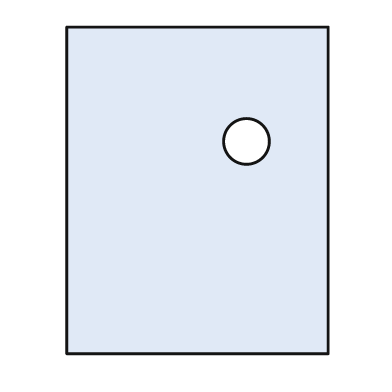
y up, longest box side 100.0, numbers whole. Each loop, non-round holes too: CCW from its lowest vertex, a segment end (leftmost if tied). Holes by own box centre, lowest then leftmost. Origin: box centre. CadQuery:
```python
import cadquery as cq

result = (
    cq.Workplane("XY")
    .moveTo(-40.0, -50.0)
    .lineTo(40.0, -50.0)
    .lineTo(40.0, 50.0)
    .lineTo(-40.0, 50.0)
    .close()
    .moveTo(15.0, 15.0)
    .circle(7.0)
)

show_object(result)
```